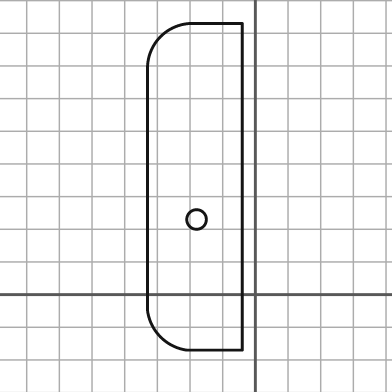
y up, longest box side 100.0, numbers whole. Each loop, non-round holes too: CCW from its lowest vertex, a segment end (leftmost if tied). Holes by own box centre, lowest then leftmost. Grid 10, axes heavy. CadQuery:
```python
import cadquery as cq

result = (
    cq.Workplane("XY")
    .moveTo(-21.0, -17.0)
    .lineTo(-4.0, -17.0)
    .lineTo(-4.0, 83.0)
    .lineTo(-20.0, 83.0)
    .threePointArc((-29.0, 79.0), (-33.0, 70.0))
    .lineTo(-33.0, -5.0)
    .threePointArc((-29.0, -13.0), (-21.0, -17.0))
    .close()
    .moveTo(-18.0, 23.0)
    .circle(3.0)
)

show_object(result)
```